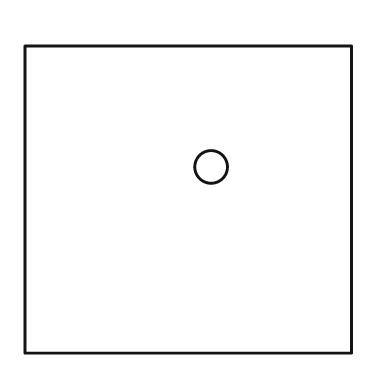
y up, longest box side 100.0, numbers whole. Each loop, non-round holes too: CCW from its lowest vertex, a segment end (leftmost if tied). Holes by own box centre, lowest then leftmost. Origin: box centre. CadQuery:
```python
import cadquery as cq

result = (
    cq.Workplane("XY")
    .moveTo(-50.0, -47.0)
    .lineTo(50.0, -47.0)
    .lineTo(50.0, 47.0)
    .lineTo(-50.0, 47.0)
    .close()
    .moveTo(7.0, 10.0)
    .circle(5.0)
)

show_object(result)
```